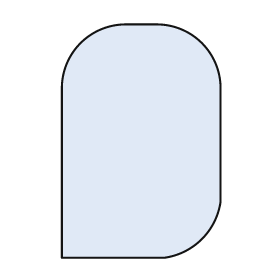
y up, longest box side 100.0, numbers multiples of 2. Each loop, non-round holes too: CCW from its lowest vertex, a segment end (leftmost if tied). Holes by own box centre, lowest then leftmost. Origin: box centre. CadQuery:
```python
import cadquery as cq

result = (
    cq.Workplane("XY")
    .moveTo(-34.0, -50.0)
    .lineTo(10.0, -50.0)
    .threePointArc((26.0, -42.0), (34.0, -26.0))
    .lineTo(34.0, 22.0)
    .threePointArc((26.0, 42.0), (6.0, 50.0))
    .lineTo(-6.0, 50.0)
    .threePointArc((-26.0, 42.0), (-34.0, 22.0))
    .close()
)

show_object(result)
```